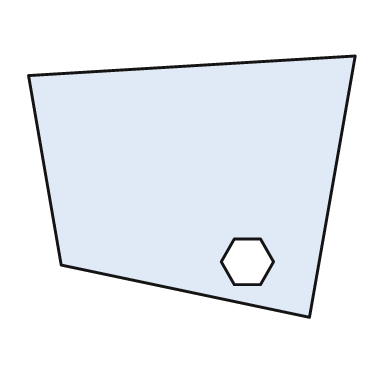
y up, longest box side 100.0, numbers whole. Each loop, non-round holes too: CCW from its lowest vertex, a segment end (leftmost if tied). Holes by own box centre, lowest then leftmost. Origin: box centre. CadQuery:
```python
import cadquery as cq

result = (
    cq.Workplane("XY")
    .moveTo(36.0, -40.0)
    .lineTo(50.0, 40.0)
    .lineTo(-50.0, 34.0)
    .lineTo(-40.0, -24.0)
    .close()
    .moveTo(13.0, -30.0)
    .lineTo(21.0, -30.0)
    .lineTo(25.0, -23.0)
    .lineTo(21.0, -16.0)
    .lineTo(13.0, -16.0)
    .lineTo(9.0, -23.0)
    .close()
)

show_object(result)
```